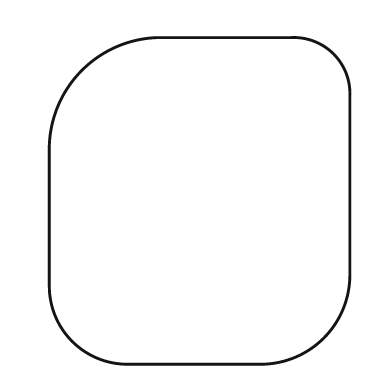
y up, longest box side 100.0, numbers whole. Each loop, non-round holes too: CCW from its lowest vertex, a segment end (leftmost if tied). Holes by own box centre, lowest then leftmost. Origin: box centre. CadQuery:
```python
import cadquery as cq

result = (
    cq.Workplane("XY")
    .moveTo(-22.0, -50.0)
    .lineTo(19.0, -50.0)
    .threePointArc((38.0, -42.0), (46.0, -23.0))
    .lineTo(46.0, 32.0)
    .threePointArc((41.0, 45.0), (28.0, 50.0))
    .lineTo(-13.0, 50.0)
    .threePointArc((-36.0, 40.0), (-46.0, 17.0))
    .lineTo(-46.0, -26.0)
    .threePointArc((-39.0, -43.0), (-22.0, -50.0))
    .close()
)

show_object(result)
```